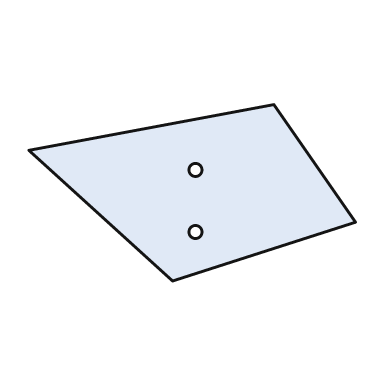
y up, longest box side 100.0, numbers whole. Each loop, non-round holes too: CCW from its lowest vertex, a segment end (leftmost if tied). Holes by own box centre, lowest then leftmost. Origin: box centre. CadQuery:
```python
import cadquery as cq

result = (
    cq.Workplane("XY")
    .moveTo(-6.0, -27.0)
    .lineTo(50.0, -9.0)
    .lineTo(25.0, 27.0)
    .lineTo(-50.0, 13.0)
    .close()
    .moveTo(1.0, -12.0)
    .circle(2.0)
    .moveTo(1.0, 7.0)
    .circle(2.0)
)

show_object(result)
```